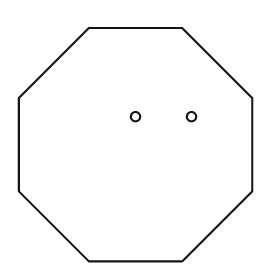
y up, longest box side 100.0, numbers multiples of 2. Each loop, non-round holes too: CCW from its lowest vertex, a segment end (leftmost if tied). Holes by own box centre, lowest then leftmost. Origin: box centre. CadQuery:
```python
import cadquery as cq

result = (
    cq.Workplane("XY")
    .moveTo(-20.0, -50.0)
    .lineTo(20.0, -50.0)
    .lineTo(50.0, -20.0)
    .lineTo(50.0, 20.0)
    .lineTo(20.0, 50.0)
    .lineTo(-20.0, 50.0)
    .lineTo(-50.0, 20.0)
    .lineTo(-50.0, -20.0)
    .close()
    .moveTo(0.0, 12.0)
    .circle(2.0)
    .moveTo(24.0, 12.0)
    .circle(2.0)
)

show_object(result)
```